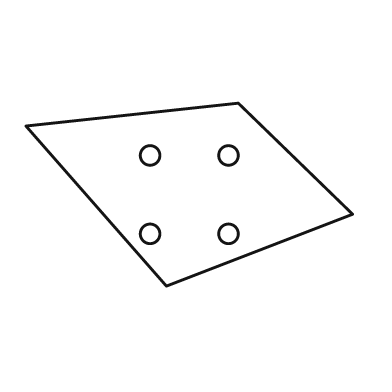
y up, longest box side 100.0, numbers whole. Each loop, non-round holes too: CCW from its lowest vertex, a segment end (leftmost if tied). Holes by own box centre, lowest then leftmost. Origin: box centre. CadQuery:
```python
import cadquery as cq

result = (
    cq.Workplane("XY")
    .moveTo(-7.0, -28.0)
    .lineTo(50.0, -6.0)
    .lineTo(15.0, 28.0)
    .lineTo(-50.0, 21.0)
    .close()
    .moveTo(-12.0, -12.0)
    .circle(3.0)
    .moveTo(12.0, -12.0)
    .circle(3.0)
    .moveTo(-12.0, 12.0)
    .circle(3.0)
    .moveTo(12.0, 12.0)
    .circle(3.0)
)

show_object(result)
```